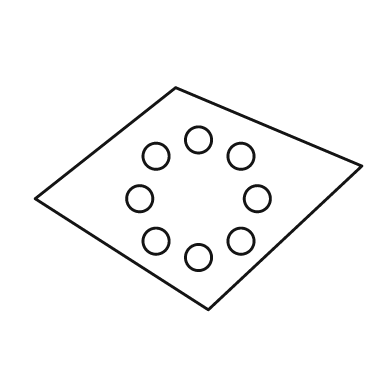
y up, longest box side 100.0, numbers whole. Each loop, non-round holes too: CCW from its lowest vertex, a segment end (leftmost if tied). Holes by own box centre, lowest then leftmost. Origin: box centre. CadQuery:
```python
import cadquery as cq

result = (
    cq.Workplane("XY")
    .moveTo(3.0, -34.0)
    .lineTo(50.0, 10.0)
    .lineTo(-7.0, 34.0)
    .lineTo(-50.0, 0.0)
    .close()
    .moveTo(0.0, -18.0)
    .circle(4.0)
    .moveTo(-13.0, -13.0)
    .circle(4.0)
    .moveTo(13.0, -13.0)
    .circle(4.0)
    .moveTo(-18.0, 0.0)
    .circle(4.0)
    .moveTo(18.0, 0.0)
    .circle(4.0)
    .moveTo(-13.0, 13.0)
    .circle(4.0)
    .moveTo(13.0, 13.0)
    .circle(4.0)
    .moveTo(0.0, 18.0)
    .circle(4.0)
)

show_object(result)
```